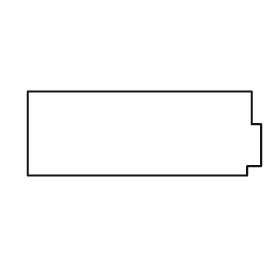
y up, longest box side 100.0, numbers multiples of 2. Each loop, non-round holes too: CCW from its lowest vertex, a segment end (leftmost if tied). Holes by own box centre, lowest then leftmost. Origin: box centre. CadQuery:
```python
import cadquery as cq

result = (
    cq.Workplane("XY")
    .moveTo(-50.0, -18.0)
    .lineTo(44.0, -18.0)
    .lineTo(44.0, -14.0)
    .lineTo(50.0, -14.0)
    .lineTo(50.0, 4.0)
    .lineTo(46.0, 4.0)
    .lineTo(46.0, 18.0)
    .lineTo(-50.0, 18.0)
    .close()
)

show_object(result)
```